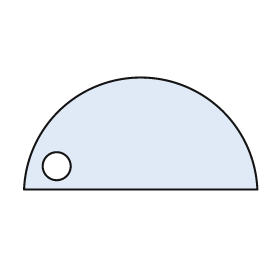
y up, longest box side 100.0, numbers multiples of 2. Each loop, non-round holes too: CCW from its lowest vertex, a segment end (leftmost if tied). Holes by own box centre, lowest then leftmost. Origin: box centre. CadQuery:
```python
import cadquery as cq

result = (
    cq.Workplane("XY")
    .moveTo(-50.0, -24.0)
    .lineTo(50.0, -24.0)
    .threePointArc((0.0, 24.0), (-50.0, -24.0))
    .close()
    .moveTo(-36.0, -14.0)
    .circle(6.0)
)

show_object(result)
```